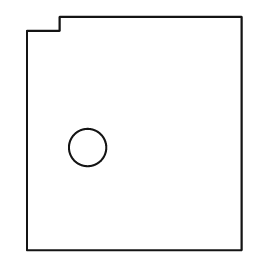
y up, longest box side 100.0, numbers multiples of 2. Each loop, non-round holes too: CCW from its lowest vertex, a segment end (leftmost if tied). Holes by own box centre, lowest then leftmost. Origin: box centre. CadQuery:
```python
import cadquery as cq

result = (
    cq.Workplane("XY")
    .moveTo(-46.0, -50.0)
    .lineTo(46.0, -50.0)
    .lineTo(46.0, 50.0)
    .lineTo(-32.0, 50.0)
    .lineTo(-32.0, 44.0)
    .lineTo(-46.0, 44.0)
    .close()
    .moveTo(-20.0, -6.0)
    .circle(8.0)
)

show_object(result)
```